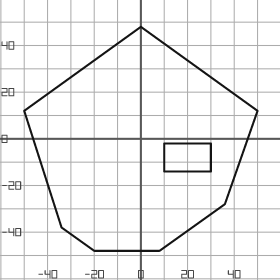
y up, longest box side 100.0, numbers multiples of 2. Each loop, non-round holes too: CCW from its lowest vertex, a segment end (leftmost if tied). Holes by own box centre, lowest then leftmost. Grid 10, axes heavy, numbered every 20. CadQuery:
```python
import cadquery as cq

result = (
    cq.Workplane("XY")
    .moveTo(-20.0, -48.0)
    .lineTo(8.0, -48.0)
    .lineTo(36.0, -28.0)
    .lineTo(50.0, 12.0)
    .lineTo(0.0, 48.0)
    .lineTo(-50.0, 12.0)
    .lineTo(-34.0, -38.0)
    .close()
    .moveTo(10.0, -14.0)
    .lineTo(30.0, -14.0)
    .lineTo(30.0, -2.0)
    .lineTo(10.0, -2.0)
    .close()
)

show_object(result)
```